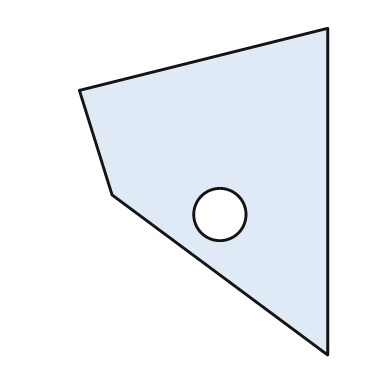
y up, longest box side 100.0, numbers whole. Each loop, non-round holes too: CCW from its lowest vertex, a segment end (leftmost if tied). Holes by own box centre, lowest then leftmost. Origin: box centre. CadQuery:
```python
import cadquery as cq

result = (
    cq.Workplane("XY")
    .moveTo(38.0, -50.0)
    .lineTo(38.0, 50.0)
    .lineTo(-38.0, 31.0)
    .lineTo(-28.0, -1.0)
    .close()
    .moveTo(5.0, -7.0)
    .circle(8.0)
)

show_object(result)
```